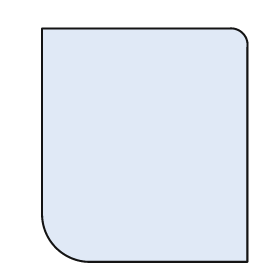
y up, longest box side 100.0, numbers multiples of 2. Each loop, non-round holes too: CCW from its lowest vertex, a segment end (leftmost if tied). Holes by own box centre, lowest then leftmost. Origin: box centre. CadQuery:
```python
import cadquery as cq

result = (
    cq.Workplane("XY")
    .moveTo(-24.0, -50.0)
    .lineTo(44.0, -50.0)
    .lineTo(44.0, 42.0)
    .threePointArc((42.0, 48.0), (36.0, 50.0))
    .lineTo(-44.0, 50.0)
    .lineTo(-44.0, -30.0)
    .threePointArc((-38.0, -44.0), (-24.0, -50.0))
    .close()
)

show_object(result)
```